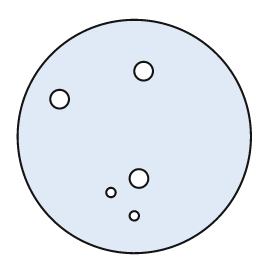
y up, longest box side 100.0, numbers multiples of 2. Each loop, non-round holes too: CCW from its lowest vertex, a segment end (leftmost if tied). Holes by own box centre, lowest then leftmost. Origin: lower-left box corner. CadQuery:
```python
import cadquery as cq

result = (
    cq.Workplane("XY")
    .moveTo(50.0, 50.0)
    .circle(50.0)
    .moveTo(50.0, 16.0)
    .circle(2.0)
    .moveTo(40.0, 26.0)
    .circle(2.0)
    .moveTo(52.0, 32.0)
    .circle(4.0)
    .moveTo(18.0, 66.0)
    .circle(4.0)
    .moveTo(54.0, 78.0)
    .circle(4.0)
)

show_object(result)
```